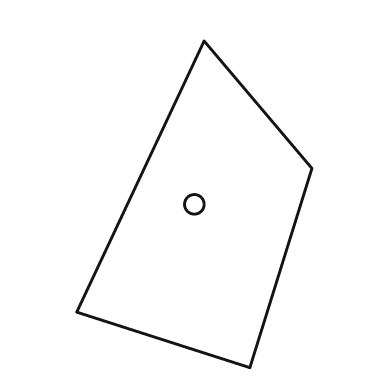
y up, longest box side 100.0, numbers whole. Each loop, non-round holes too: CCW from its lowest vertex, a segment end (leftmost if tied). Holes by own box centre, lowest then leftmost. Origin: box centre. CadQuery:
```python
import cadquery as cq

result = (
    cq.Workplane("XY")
    .moveTo(17.0, -50.0)
    .lineTo(36.0, 11.0)
    .lineTo(3.0, 50.0)
    .lineTo(-36.0, -33.0)
    .close()
    .moveTo(0.0, 0.0)
    .circle(3.0)
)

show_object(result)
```